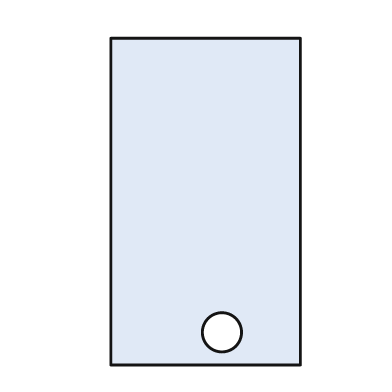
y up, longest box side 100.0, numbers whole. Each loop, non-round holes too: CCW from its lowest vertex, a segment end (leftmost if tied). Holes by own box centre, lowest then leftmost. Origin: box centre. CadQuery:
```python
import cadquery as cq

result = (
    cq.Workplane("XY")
    .moveTo(-29.0, -50.0)
    .lineTo(29.0, -50.0)
    .lineTo(29.0, 50.0)
    .lineTo(-29.0, 50.0)
    .close()
    .moveTo(5.0, -40.0)
    .circle(6.0)
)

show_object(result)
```